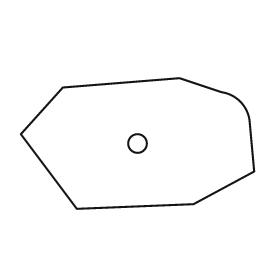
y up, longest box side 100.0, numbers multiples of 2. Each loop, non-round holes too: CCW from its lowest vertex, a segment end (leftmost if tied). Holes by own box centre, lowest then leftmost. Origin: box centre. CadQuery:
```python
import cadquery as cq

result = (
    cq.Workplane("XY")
    .moveTo(-26.0, -28.0)
    .lineTo(24.0, -26.0)
    .lineTo(50.0, -12.0)
    .lineTo(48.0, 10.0)
    .threePointArc((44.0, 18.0), (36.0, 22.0))
    .lineTo(18.0, 28.0)
    .lineTo(-32.0, 24.0)
    .lineTo(-50.0, 4.0)
    .close()
    .moveTo(0.0, 0.0)
    .circle(4.0)
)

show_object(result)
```